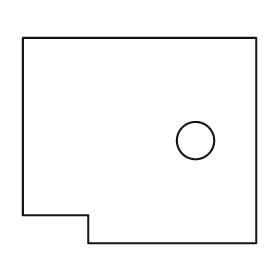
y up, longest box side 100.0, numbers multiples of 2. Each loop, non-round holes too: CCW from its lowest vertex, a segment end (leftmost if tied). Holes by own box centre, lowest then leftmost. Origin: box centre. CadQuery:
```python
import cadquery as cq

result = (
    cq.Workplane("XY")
    .moveTo(-22.0, -44.0)
    .lineTo(50.0, -44.0)
    .lineTo(50.0, 44.0)
    .lineTo(-50.0, 44.0)
    .lineTo(-50.0, -32.0)
    .lineTo(-22.0, -32.0)
    .close()
    .moveTo(24.0, 0.0)
    .circle(8.0)
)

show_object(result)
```